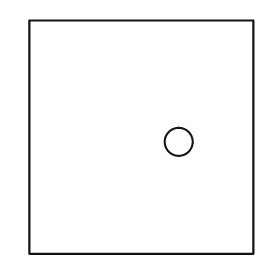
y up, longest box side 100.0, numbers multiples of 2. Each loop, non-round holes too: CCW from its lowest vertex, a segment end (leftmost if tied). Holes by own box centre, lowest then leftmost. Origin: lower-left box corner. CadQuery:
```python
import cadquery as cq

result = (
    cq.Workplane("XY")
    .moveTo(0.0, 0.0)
    .lineTo(96.0, 0.0)
    .lineTo(96.0, 100.0)
    .lineTo(0.0, 100.0)
    .close()
    .moveTo(64.0, 48.0)
    .circle(6.0)
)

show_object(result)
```